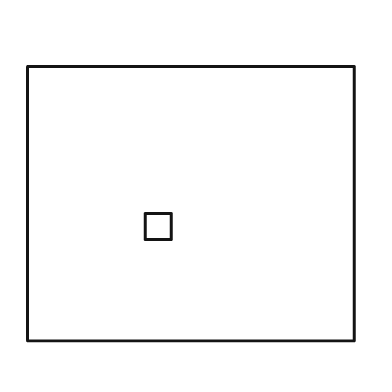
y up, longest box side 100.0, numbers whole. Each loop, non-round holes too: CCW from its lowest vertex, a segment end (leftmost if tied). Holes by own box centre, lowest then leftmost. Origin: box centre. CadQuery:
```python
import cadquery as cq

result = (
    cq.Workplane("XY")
    .moveTo(-50.0, -42.0)
    .lineTo(50.0, -42.0)
    .lineTo(50.0, 42.0)
    .lineTo(-50.0, 42.0)
    .close()
    .moveTo(-14.0, -11.0)
    .lineTo(-6.0, -11.0)
    .lineTo(-6.0, -3.0)
    .lineTo(-14.0, -3.0)
    .close()
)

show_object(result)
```